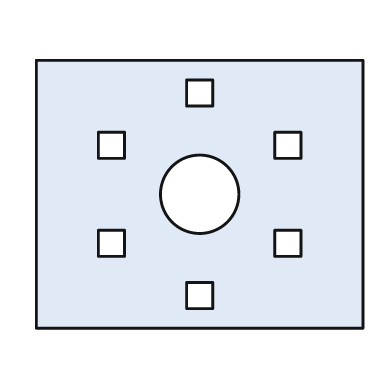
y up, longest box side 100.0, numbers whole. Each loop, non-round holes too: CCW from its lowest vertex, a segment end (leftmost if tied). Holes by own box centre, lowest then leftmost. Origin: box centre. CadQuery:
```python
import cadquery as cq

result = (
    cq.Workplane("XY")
    .moveTo(-50.0, -41.0)
    .lineTo(50.0, -41.0)
    .lineTo(50.0, 41.0)
    .lineTo(-50.0, 41.0)
    .close()
    .moveTo(-4.0, -35.0)
    .lineTo(4.0, -35.0)
    .lineTo(4.0, -27.0)
    .lineTo(-4.0, -27.0)
    .close()
    .moveTo(-31.0, -19.0)
    .lineTo(-23.0, -19.0)
    .lineTo(-23.0, -11.0)
    .lineTo(-31.0, -11.0)
    .close()
    .moveTo(23.0, -19.0)
    .lineTo(31.0, -19.0)
    .lineTo(31.0, -11.0)
    .lineTo(23.0, -11.0)
    .close()
    .moveTo(0.0, 0.0)
    .circle(12.0)
    .moveTo(-31.0, 11.0)
    .lineTo(-23.0, 11.0)
    .lineTo(-23.0, 19.0)
    .lineTo(-31.0, 19.0)
    .close()
    .moveTo(23.0, 11.0)
    .lineTo(31.0, 11.0)
    .lineTo(31.0, 19.0)
    .lineTo(23.0, 19.0)
    .close()
    .moveTo(-4.0, 27.0)
    .lineTo(4.0, 27.0)
    .lineTo(4.0, 35.0)
    .lineTo(-4.0, 35.0)
    .close()
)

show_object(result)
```